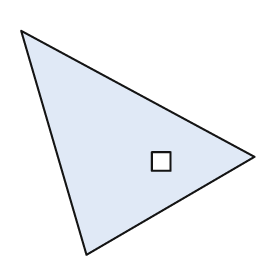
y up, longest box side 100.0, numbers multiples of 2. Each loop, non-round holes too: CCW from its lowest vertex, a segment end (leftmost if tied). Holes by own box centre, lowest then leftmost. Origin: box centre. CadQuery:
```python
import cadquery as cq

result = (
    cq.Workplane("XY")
    .moveTo(-22.0, -48.0)
    .lineTo(50.0, -6.0)
    .lineTo(-50.0, 48.0)
    .close()
    .moveTo(6.0, -12.0)
    .lineTo(14.0, -12.0)
    .lineTo(14.0, -4.0)
    .lineTo(6.0, -4.0)
    .close()
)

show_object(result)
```